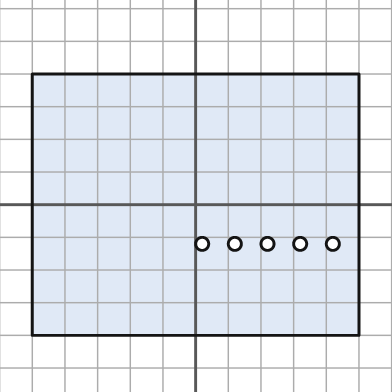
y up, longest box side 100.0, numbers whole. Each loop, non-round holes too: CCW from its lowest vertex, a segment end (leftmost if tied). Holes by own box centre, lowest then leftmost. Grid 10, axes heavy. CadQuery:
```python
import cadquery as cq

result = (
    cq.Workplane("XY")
    .moveTo(-50.0, -40.0)
    .lineTo(50.0, -40.0)
    .lineTo(50.0, 40.0)
    .lineTo(-50.0, 40.0)
    .close()
    .moveTo(2.0, -12.0)
    .circle(2.0)
    .moveTo(12.0, -12.0)
    .circle(2.0)
    .moveTo(22.0, -12.0)
    .circle(2.0)
    .moveTo(32.0, -12.0)
    .circle(2.0)
    .moveTo(42.0, -12.0)
    .circle(2.0)
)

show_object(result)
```